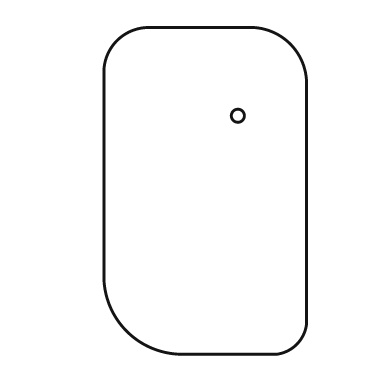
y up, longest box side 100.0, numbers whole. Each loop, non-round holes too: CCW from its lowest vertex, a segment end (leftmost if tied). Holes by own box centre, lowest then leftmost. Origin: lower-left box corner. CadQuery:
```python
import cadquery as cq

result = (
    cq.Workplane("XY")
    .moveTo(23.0, 0.0)
    .lineTo(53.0, 0.0)
    .threePointArc((59.0, 3.0), (62.0, 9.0))
    .lineTo(62.0, 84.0)
    .threePointArc((57.0, 95.0), (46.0, 100.0))
    .lineTo(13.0, 100.0)
    .threePointArc((4.0, 96.0), (0.0, 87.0))
    .lineTo(0.0, 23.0)
    .threePointArc((7.0, 7.0), (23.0, 0.0))
    .close()
    .moveTo(41.0, 73.0)
    .circle(2.0)
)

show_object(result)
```